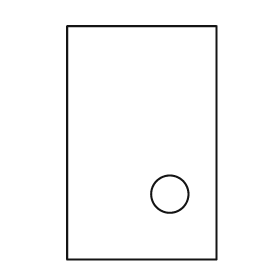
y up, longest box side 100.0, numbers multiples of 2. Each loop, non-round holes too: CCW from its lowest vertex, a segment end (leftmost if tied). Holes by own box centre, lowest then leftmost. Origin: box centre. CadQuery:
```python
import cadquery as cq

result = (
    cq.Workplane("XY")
    .moveTo(-32.0, -50.0)
    .lineTo(32.0, -50.0)
    .lineTo(32.0, 50.0)
    .lineTo(-32.0, 50.0)
    .close()
    .moveTo(12.0, -22.0)
    .circle(8.0)
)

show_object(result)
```